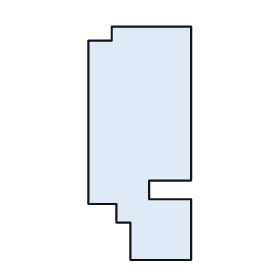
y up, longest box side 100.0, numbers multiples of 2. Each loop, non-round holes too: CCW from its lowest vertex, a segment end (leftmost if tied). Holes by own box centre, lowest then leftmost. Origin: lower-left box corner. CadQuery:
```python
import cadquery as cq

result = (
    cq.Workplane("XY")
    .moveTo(18.0, 0.0)
    .lineTo(44.0, 0.0)
    .lineTo(44.0, 26.0)
    .lineTo(26.0, 26.0)
    .lineTo(26.0, 34.0)
    .lineTo(44.0, 34.0)
    .lineTo(44.0, 100.0)
    .lineTo(10.0, 100.0)
    .lineTo(10.0, 94.0)
    .lineTo(0.0, 94.0)
    .lineTo(0.0, 24.0)
    .lineTo(12.0, 24.0)
    .lineTo(12.0, 16.0)
    .lineTo(18.0, 16.0)
    .close()
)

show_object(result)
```